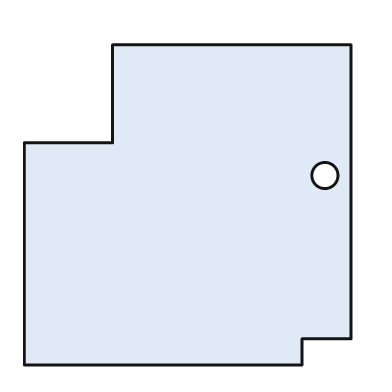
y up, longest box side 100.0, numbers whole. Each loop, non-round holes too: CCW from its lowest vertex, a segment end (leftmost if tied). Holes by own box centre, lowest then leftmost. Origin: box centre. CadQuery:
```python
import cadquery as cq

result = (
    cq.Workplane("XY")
    .moveTo(-50.0, -49.0)
    .lineTo(35.0, -49.0)
    .lineTo(35.0, -41.0)
    .lineTo(50.0, -41.0)
    .lineTo(50.0, 49.0)
    .lineTo(-23.0, 49.0)
    .lineTo(-23.0, 19.0)
    .lineTo(-50.0, 19.0)
    .close()
    .moveTo(42.0, 9.0)
    .circle(4.0)
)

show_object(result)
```